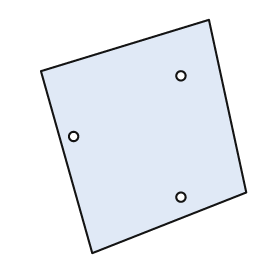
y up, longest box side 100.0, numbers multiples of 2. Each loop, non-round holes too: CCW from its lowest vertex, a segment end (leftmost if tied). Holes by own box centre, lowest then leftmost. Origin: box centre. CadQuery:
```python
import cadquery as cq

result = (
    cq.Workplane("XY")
    .moveTo(-22.0, -50.0)
    .lineTo(44.0, -24.0)
    .lineTo(28.0, 50.0)
    .lineTo(-44.0, 28.0)
    .close()
    .moveTo(16.0, -26.0)
    .circle(2.0)
    .moveTo(-30.0, 0.0)
    .circle(2.0)
    .moveTo(16.0, 26.0)
    .circle(2.0)
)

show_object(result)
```